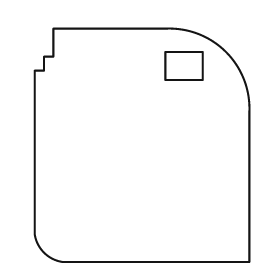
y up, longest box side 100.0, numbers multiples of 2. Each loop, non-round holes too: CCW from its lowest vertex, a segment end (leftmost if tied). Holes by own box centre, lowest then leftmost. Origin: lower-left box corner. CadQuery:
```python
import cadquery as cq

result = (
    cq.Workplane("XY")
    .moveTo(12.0, 0.0)
    .lineTo(92.0, 0.0)
    .lineTo(92.0, 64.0)
    .threePointArc((82.0, 90.0), (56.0, 100.0))
    .lineTo(8.0, 100.0)
    .lineTo(8.0, 88.0)
    .lineTo(4.0, 88.0)
    .lineTo(4.0, 82.0)
    .lineTo(0.0, 82.0)
    .lineTo(0.0, 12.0)
    .threePointArc((4.0, 4.0), (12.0, 0.0))
    .close()
    .moveTo(56.0, 78.0)
    .lineTo(72.0, 78.0)
    .lineTo(72.0, 90.0)
    .lineTo(56.0, 90.0)
    .close()
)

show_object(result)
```